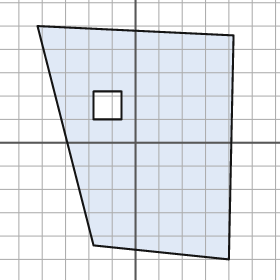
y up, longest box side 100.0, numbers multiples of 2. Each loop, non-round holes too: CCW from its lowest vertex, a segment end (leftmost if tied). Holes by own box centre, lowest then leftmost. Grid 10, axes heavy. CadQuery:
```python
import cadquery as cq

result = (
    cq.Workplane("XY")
    .moveTo(40.0, -50.0)
    .lineTo(42.0, 46.0)
    .lineTo(-42.0, 50.0)
    .lineTo(-18.0, -44.0)
    .close()
    .moveTo(-18.0, 10.0)
    .lineTo(-6.0, 10.0)
    .lineTo(-6.0, 22.0)
    .lineTo(-18.0, 22.0)
    .close()
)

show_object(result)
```